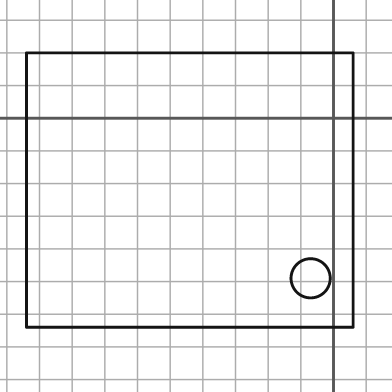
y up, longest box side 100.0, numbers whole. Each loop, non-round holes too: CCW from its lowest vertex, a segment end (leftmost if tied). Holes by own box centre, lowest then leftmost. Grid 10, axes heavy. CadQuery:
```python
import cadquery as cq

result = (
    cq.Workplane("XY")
    .moveTo(-94.0, -64.0)
    .lineTo(6.0, -64.0)
    .lineTo(6.0, 20.0)
    .lineTo(-94.0, 20.0)
    .close()
    .moveTo(-7.0, -49.0)
    .circle(6.0)
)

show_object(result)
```